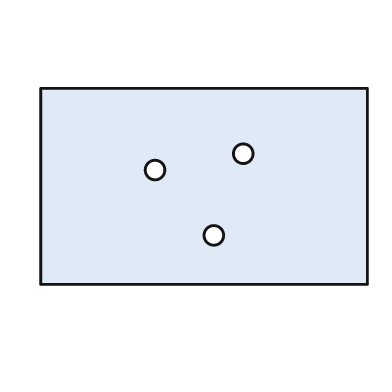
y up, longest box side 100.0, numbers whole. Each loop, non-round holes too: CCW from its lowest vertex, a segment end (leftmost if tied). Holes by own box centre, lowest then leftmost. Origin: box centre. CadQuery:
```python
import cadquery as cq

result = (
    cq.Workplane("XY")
    .moveTo(-50.0, -30.0)
    .lineTo(50.0, -30.0)
    .lineTo(50.0, 30.0)
    .lineTo(-50.0, 30.0)
    .close()
    .moveTo(3.0, -15.0)
    .circle(3.0)
    .moveTo(-15.0, 5.0)
    .circle(3.0)
    .moveTo(12.0, 10.0)
    .circle(3.0)
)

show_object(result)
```